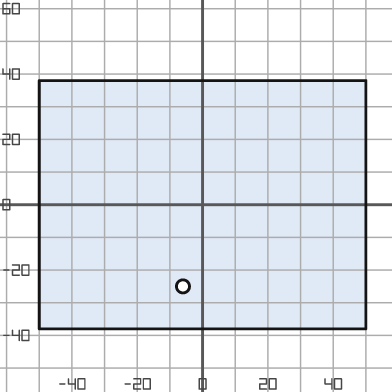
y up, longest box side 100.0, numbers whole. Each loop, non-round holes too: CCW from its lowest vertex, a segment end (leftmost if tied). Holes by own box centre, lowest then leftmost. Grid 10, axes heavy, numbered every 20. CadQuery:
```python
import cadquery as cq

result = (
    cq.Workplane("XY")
    .moveTo(-50.0, -38.0)
    .lineTo(50.0, -38.0)
    .lineTo(50.0, 38.0)
    .lineTo(-50.0, 38.0)
    .close()
    .moveTo(-6.0, -25.0)
    .circle(2.0)
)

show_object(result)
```